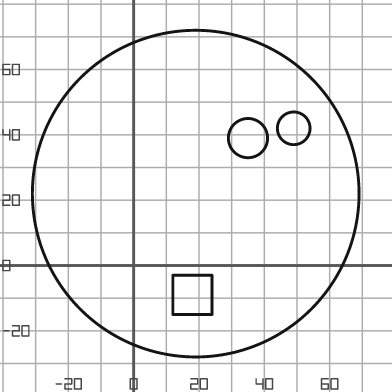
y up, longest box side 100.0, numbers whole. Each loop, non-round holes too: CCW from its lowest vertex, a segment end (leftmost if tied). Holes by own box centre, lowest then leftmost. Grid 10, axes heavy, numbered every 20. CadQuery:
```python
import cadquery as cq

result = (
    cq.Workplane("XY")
    .moveTo(19.0, 22.0)
    .circle(50.0)
    .moveTo(12.0, -15.0)
    .lineTo(24.0, -15.0)
    .lineTo(24.0, -3.0)
    .lineTo(12.0, -3.0)
    .close()
    .moveTo(35.0, 39.0)
    .circle(6.0)
    .moveTo(49.0, 42.0)
    .circle(5.0)
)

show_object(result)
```